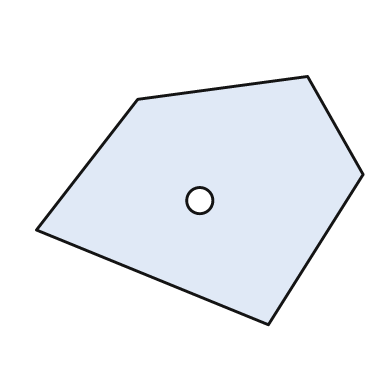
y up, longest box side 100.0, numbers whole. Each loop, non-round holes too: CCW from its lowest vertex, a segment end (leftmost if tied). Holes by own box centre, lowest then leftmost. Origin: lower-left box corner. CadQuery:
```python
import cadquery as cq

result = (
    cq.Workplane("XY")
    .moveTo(71.0, 0.0)
    .lineTo(100.0, 46.0)
    .lineTo(83.0, 76.0)
    .lineTo(31.0, 69.0)
    .lineTo(0.0, 29.0)
    .close()
    .moveTo(50.0, 38.0)
    .circle(4.0)
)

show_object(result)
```